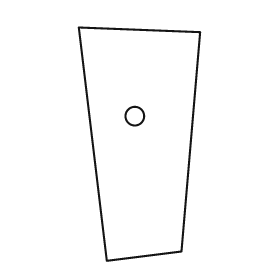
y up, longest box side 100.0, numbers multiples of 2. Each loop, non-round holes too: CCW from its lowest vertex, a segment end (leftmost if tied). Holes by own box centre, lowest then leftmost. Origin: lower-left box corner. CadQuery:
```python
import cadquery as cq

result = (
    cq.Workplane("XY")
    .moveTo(12.0, 0.0)
    .lineTo(44.0, 4.0)
    .lineTo(52.0, 98.0)
    .lineTo(0.0, 100.0)
    .close()
    .moveTo(24.0, 62.0)
    .circle(4.0)
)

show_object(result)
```